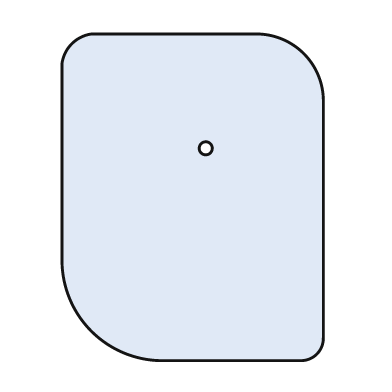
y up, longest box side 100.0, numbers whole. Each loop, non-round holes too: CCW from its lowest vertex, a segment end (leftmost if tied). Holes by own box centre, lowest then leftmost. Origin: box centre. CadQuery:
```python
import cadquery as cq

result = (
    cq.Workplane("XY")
    .moveTo(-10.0, -50.0)
    .lineTo(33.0, -50.0)
    .threePointArc((38.0, -48.0), (40.0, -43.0))
    .lineTo(40.0, 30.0)
    .threePointArc((34.0, 44.0), (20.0, 50.0))
    .lineTo(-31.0, 50.0)
    .threePointArc((-37.0, 47.0), (-40.0, 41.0))
    .lineTo(-40.0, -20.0)
    .threePointArc((-31.0, -41.0), (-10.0, -50.0))
    .close()
    .moveTo(4.0, 15.0)
    .circle(2.0)
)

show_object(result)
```